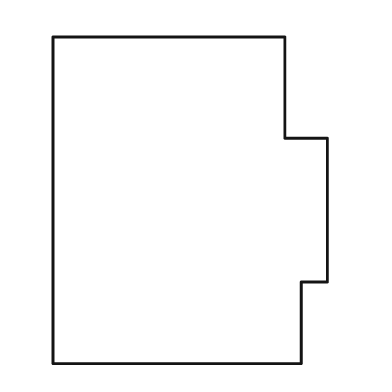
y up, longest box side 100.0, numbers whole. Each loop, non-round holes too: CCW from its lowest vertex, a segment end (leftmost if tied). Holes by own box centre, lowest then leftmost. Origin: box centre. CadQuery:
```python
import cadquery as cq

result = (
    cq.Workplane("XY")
    .moveTo(-42.0, -50.0)
    .lineTo(34.0, -50.0)
    .lineTo(34.0, -25.0)
    .lineTo(42.0, -25.0)
    .lineTo(42.0, 19.0)
    .lineTo(29.0, 19.0)
    .lineTo(29.0, 50.0)
    .lineTo(-42.0, 50.0)
    .close()
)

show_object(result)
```